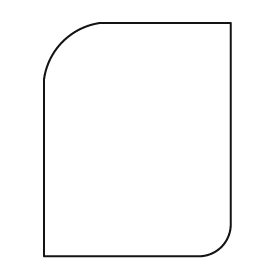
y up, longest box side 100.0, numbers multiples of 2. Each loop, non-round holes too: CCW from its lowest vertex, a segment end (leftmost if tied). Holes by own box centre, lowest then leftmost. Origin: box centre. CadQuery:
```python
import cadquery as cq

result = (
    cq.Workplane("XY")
    .moveTo(-40.0, -50.0)
    .lineTo(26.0, -50.0)
    .threePointArc((36.0, -46.0), (40.0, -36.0))
    .lineTo(40.0, 50.0)
    .lineTo(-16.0, 50.0)
    .threePointArc((-32.0, 42.0), (-40.0, 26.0))
    .close()
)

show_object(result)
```